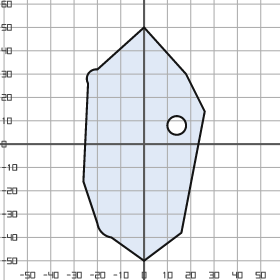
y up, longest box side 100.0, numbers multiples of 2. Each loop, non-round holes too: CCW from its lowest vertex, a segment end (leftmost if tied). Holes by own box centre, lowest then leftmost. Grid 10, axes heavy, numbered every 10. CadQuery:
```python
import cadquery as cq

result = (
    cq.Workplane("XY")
    .moveTo(0.0, -50.0)
    .lineTo(16.0, -38.0)
    .lineTo(26.0, 14.0)
    .lineTo(18.0, 30.0)
    .lineTo(0.0, 50.0)
    .lineTo(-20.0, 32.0)
    .threePointArc((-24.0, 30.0), (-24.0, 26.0))
    .lineTo(-26.0, -16.0)
    .lineTo(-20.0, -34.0)
    .threePointArc((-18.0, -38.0), (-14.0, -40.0))
    .close()
    .moveTo(14.0, 8.0)
    .circle(4.0)
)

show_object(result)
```